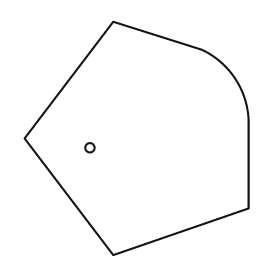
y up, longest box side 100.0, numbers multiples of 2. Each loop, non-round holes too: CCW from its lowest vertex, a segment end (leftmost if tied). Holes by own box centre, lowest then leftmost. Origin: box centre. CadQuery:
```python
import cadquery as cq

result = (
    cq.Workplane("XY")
    .moveTo(-10.0, -50.0)
    .lineTo(48.0, -30.0)
    .lineTo(48.0, 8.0)
    .threePointArc((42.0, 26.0), (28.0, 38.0))
    .lineTo(-10.0, 50.0)
    .lineTo(-48.0, 0.0)
    .close()
    .moveTo(-20.0, -4.0)
    .circle(2.0)
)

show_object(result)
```